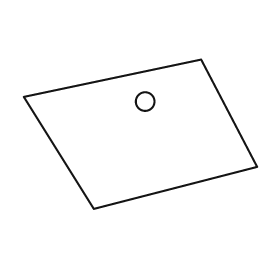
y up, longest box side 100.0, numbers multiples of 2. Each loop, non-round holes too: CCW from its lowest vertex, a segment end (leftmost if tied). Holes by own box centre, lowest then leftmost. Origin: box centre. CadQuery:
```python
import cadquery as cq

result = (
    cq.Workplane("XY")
    .moveTo(-20.0, -32.0)
    .lineTo(50.0, -14.0)
    .lineTo(26.0, 32.0)
    .lineTo(-50.0, 16.0)
    .close()
    .moveTo(2.0, 14.0)
    .circle(4.0)
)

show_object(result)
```